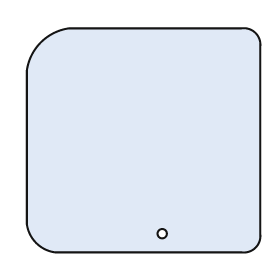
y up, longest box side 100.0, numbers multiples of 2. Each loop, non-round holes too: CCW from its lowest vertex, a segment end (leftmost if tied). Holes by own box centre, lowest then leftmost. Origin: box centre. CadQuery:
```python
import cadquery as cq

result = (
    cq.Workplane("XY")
    .moveTo(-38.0, -48.0)
    .lineTo(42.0, -48.0)
    .threePointArc((48.0, -46.0), (50.0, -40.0))
    .lineTo(50.0, 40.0)
    .threePointArc((48.0, 46.0), (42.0, 48.0))
    .lineTo(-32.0, 48.0)
    .threePointArc((-44.0, 42.0), (-50.0, 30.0))
    .lineTo(-50.0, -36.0)
    .threePointArc((-46.0, -44.0), (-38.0, -48.0))
    .close()
    .moveTo(8.0, -40.0)
    .circle(2.0)
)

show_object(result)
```